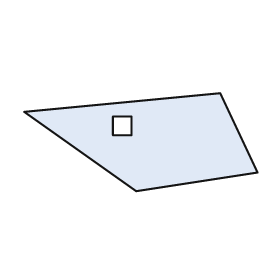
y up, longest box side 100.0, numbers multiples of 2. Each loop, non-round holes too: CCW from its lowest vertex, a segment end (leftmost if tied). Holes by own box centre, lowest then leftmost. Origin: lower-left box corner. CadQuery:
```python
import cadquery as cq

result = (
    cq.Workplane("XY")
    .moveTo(48.0, 0.0)
    .lineTo(100.0, 8.0)
    .lineTo(84.0, 42.0)
    .lineTo(0.0, 34.0)
    .close()
    .moveTo(38.0, 24.0)
    .lineTo(46.0, 24.0)
    .lineTo(46.0, 32.0)
    .lineTo(38.0, 32.0)
    .close()
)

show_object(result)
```